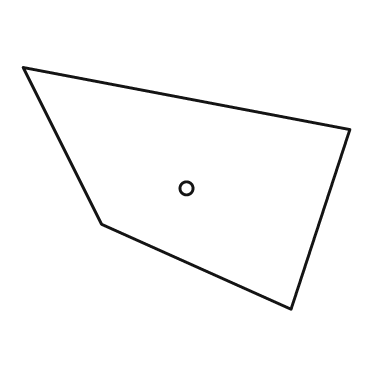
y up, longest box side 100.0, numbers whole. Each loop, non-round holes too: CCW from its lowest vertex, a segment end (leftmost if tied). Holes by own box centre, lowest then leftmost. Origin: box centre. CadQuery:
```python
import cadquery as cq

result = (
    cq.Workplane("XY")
    .moveTo(32.0, -37.0)
    .lineTo(50.0, 18.0)
    .lineTo(-50.0, 37.0)
    .lineTo(-26.0, -11.0)
    .close()
    .moveTo(0.0, 0.0)
    .circle(2.0)
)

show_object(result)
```